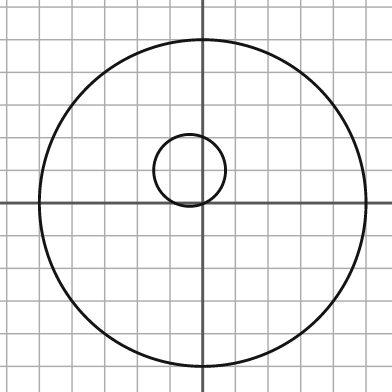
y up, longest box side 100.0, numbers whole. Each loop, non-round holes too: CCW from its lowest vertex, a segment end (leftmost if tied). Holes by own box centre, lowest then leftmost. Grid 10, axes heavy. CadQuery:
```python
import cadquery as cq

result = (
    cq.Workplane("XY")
    .moveTo(0.0, 0.0)
    .circle(50.0)
    .moveTo(-4.0, 10.0)
    .circle(11.0)
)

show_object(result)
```